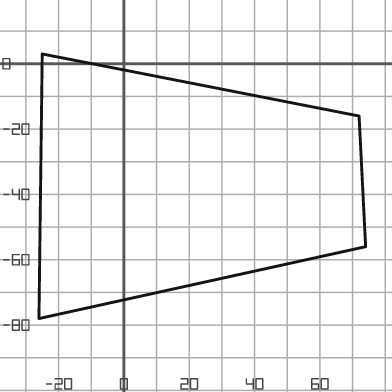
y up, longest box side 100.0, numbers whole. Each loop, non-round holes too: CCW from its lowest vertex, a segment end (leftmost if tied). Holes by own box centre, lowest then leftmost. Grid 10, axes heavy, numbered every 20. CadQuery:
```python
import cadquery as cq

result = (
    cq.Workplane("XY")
    .moveTo(-26.0, -78.0)
    .lineTo(74.0, -56.0)
    .lineTo(72.0, -16.0)
    .lineTo(-25.0, 3.0)
    .close()
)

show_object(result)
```